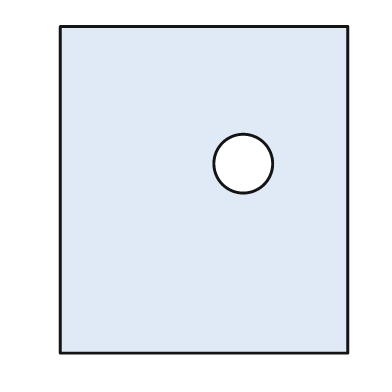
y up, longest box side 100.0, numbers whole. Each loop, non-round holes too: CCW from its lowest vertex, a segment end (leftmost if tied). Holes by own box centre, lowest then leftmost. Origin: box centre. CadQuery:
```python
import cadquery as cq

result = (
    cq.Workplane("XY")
    .moveTo(-44.0, -50.0)
    .lineTo(44.0, -50.0)
    .lineTo(44.0, 50.0)
    .lineTo(-44.0, 50.0)
    .close()
    .moveTo(12.0, 8.0)
    .circle(9.0)
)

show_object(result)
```